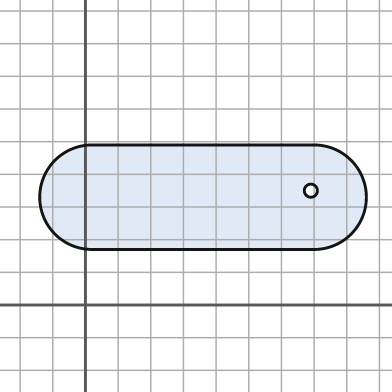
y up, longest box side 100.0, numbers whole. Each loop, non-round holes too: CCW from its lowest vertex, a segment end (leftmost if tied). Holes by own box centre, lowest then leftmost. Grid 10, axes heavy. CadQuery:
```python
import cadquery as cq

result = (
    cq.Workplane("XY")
    .moveTo(2.0, 17.0)
    .lineTo(70.0, 17.0)
    .threePointArc((86.0, 33.0), (70.0, 49.0))
    .lineTo(2.0, 49.0)
    .threePointArc((-14.0, 33.0), (2.0, 17.0))
    .close()
    .moveTo(69.0, 35.0)
    .circle(2.0)
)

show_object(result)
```